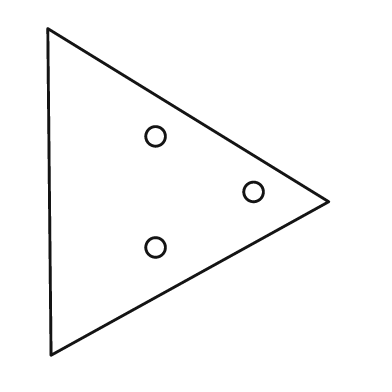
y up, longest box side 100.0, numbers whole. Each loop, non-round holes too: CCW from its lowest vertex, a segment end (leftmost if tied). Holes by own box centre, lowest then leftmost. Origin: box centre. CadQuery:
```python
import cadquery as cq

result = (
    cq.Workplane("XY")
    .moveTo(-42.0, -50.0)
    .lineTo(43.0, -3.0)
    .lineTo(-43.0, 50.0)
    .close()
    .moveTo(-10.0, -17.0)
    .circle(3.0)
    .moveTo(20.0, 0.0)
    .circle(3.0)
    .moveTo(-10.0, 17.0)
    .circle(3.0)
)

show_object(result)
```